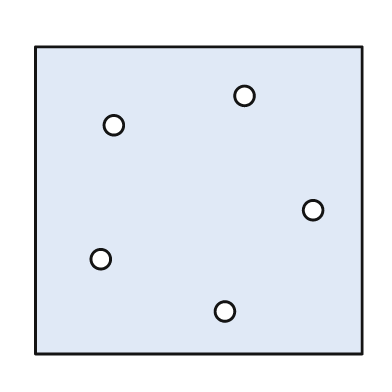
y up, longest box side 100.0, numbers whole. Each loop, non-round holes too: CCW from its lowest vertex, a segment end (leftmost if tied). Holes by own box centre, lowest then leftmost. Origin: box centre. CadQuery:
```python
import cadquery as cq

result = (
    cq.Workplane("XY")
    .moveTo(-50.0, -47.0)
    .lineTo(50.0, -47.0)
    .lineTo(50.0, 47.0)
    .lineTo(-50.0, 47.0)
    .close()
    .moveTo(8.0, -34.0)
    .circle(3.0)
    .moveTo(-30.0, -18.0)
    .circle(3.0)
    .moveTo(35.0, -3.0)
    .circle(3.0)
    .moveTo(-26.0, 23.0)
    .circle(3.0)
    .moveTo(14.0, 32.0)
    .circle(3.0)
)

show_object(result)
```